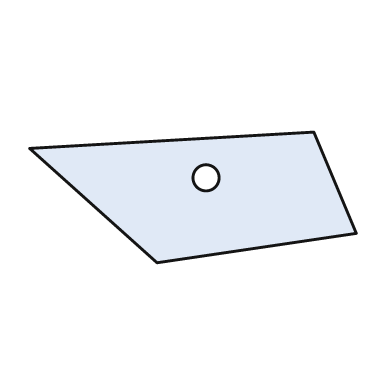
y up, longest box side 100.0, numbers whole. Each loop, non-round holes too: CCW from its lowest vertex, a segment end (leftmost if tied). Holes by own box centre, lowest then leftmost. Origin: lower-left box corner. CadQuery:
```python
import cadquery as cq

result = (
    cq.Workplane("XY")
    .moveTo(39.0, 0.0)
    .lineTo(100.0, 9.0)
    .lineTo(87.0, 40.0)
    .lineTo(0.0, 35.0)
    .close()
    .moveTo(54.0, 26.0)
    .circle(4.0)
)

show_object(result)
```